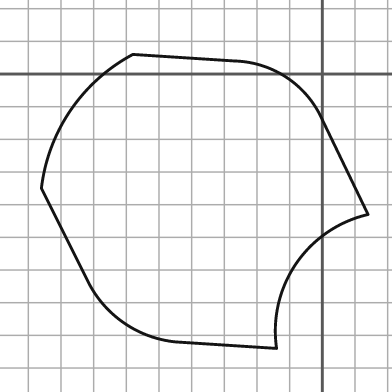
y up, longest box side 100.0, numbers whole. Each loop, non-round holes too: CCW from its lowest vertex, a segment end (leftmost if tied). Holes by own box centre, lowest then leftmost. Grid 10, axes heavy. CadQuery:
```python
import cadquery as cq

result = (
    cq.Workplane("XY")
    .moveTo(-14.0, -84.0)
    .threePointArc((-8.0, -58.0), (14.0, -43.0))
    .lineTo(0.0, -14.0)
    .threePointArc((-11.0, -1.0), (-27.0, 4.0))
    .lineTo(-58.0, 6.0)
    .threePointArc((-77.0, -11.0), (-86.0, -35.0))
    .lineTo(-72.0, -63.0)
    .threePointArc((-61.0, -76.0), (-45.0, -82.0))
    .close()
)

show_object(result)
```